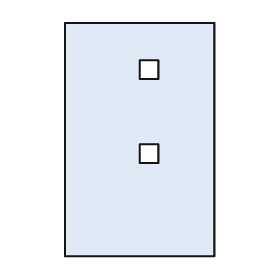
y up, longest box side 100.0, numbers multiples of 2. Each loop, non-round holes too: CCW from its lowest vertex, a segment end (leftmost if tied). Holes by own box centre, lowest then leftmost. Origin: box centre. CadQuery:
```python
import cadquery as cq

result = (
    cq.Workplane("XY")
    .moveTo(-32.0, -50.0)
    .lineTo(32.0, -50.0)
    .lineTo(32.0, 50.0)
    .lineTo(-32.0, 50.0)
    .close()
    .moveTo(0.0, -10.0)
    .lineTo(8.0, -10.0)
    .lineTo(8.0, -2.0)
    .lineTo(0.0, -2.0)
    .close()
    .moveTo(0.0, 26.0)
    .lineTo(8.0, 26.0)
    .lineTo(8.0, 34.0)
    .lineTo(0.0, 34.0)
    .close()
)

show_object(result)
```